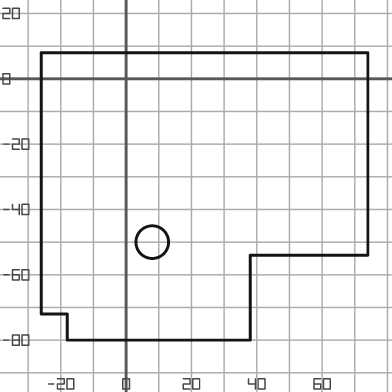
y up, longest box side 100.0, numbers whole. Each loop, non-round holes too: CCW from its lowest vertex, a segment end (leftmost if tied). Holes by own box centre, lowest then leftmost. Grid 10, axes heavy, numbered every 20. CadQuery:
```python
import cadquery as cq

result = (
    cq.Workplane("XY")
    .moveTo(-18.0, -80.0)
    .lineTo(38.0, -80.0)
    .lineTo(38.0, -54.0)
    .lineTo(74.0, -54.0)
    .lineTo(74.0, 8.0)
    .lineTo(-26.0, 8.0)
    .lineTo(-26.0, -72.0)
    .lineTo(-18.0, -72.0)
    .close()
    .moveTo(8.0, -50.0)
    .circle(5.0)
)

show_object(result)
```